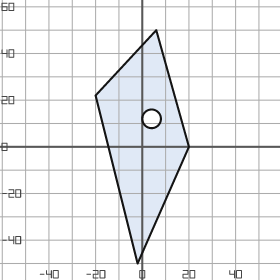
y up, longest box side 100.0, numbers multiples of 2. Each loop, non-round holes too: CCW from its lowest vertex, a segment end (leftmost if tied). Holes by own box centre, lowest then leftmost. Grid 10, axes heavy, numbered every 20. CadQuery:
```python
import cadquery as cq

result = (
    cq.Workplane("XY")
    .moveTo(-2.0, -50.0)
    .lineTo(20.0, 0.0)
    .lineTo(6.0, 50.0)
    .lineTo(-20.0, 22.0)
    .close()
    .moveTo(4.0, 12.0)
    .circle(4.0)
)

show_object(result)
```